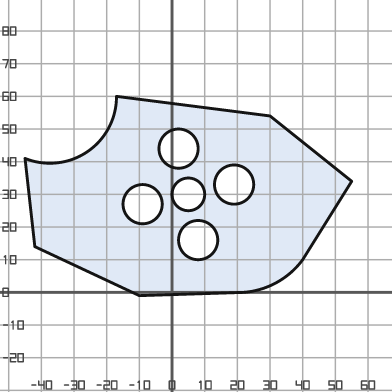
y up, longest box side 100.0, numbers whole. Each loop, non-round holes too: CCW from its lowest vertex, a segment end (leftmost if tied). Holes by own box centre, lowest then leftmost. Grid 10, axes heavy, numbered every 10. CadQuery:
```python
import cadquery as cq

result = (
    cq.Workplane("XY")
    .moveTo(-10.0, -1.0)
    .lineTo(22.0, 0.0)
    .threePointArc((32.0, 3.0), (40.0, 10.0))
    .lineTo(55.0, 34.0)
    .lineTo(30.0, 54.0)
    .lineTo(-17.0, 60.0)
    .threePointArc((-26.0, 43.0), (-45.0, 41.0))
    .lineTo(-42.0, 14.0)
    .close()
    .moveTo(8.0, 16.0)
    .circle(6.0)
    .moveTo(-9.0, 27.0)
    .circle(6.0)
    .moveTo(5.0, 30.0)
    .circle(5.0)
    .moveTo(19.0, 33.0)
    .circle(6.0)
    .moveTo(2.0, 44.0)
    .circle(6.0)
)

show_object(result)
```